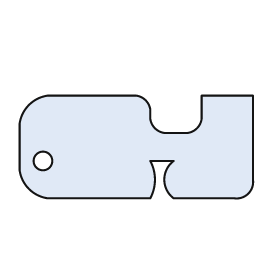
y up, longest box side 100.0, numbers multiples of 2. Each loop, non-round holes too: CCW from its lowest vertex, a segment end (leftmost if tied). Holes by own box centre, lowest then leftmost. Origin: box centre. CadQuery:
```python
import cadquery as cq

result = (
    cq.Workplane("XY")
    .moveTo(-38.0, -22.0)
    .lineTo(6.0, -22.0)
    .threePointArc((8.0, -14.0), (6.0, -6.0))
    .lineTo(16.0, -6.0)
    .threePointArc((12.0, -14.0), (16.0, -22.0))
    .lineTo(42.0, -22.0)
    .threePointArc((48.0, -20.0), (50.0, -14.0))
    .lineTo(50.0, 22.0)
    .lineTo(28.0, 22.0)
    .lineTo(28.0, 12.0)
    .threePointArc((26.0, 8.0), (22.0, 6.0))
    .lineTo(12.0, 6.0)
    .threePointArc((8.0, 8.0), (6.0, 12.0))
    .lineTo(6.0, 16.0)
    .threePointArc((4.0, 20.0), (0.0, 22.0))
    .lineTo(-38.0, 22.0)
    .threePointArc((-46.0, 18.0), (-50.0, 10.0))
    .lineTo(-50.0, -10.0)
    .threePointArc((-46.0, -18.0), (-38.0, -22.0))
    .close()
    .moveTo(-40.0, -6.0)
    .circle(4.0)
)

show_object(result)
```